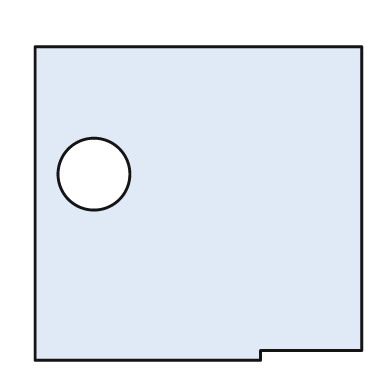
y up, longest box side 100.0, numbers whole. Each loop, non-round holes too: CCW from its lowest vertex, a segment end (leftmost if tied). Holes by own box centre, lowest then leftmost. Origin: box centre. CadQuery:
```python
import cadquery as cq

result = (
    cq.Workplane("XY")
    .moveTo(-50.0, -48.0)
    .lineTo(19.0, -48.0)
    .lineTo(19.0, -45.0)
    .lineTo(50.0, -45.0)
    .lineTo(50.0, 48.0)
    .lineTo(-50.0, 48.0)
    .close()
    .moveTo(-32.0, 9.0)
    .circle(11.0)
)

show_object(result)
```